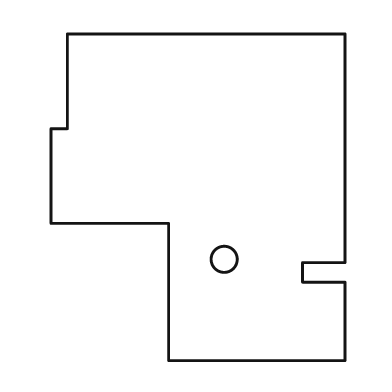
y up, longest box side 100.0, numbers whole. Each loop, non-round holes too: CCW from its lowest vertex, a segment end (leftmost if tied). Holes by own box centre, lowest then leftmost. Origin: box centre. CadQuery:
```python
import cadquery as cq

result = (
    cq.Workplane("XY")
    .moveTo(-9.0, -50.0)
    .lineTo(45.0, -50.0)
    .lineTo(45.0, -26.0)
    .lineTo(32.0, -26.0)
    .lineTo(32.0, -20.0)
    .lineTo(45.0, -20.0)
    .lineTo(45.0, 50.0)
    .lineTo(-40.0, 50.0)
    .lineTo(-40.0, 21.0)
    .lineTo(-45.0, 21.0)
    .lineTo(-45.0, -8.0)
    .lineTo(-9.0, -8.0)
    .close()
    .moveTo(8.0, -19.0)
    .circle(4.0)
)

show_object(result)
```